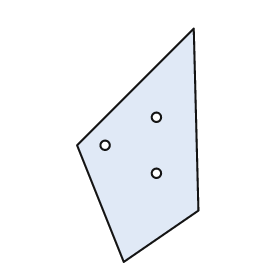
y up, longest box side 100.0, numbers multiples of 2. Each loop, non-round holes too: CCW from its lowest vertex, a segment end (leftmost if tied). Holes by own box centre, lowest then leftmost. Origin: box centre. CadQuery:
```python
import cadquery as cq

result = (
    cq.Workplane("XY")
    .moveTo(-6.0, -50.0)
    .lineTo(26.0, -28.0)
    .lineTo(24.0, 50.0)
    .lineTo(-26.0, 0.0)
    .close()
    .moveTo(8.0, -12.0)
    .circle(2.0)
    .moveTo(-14.0, 0.0)
    .circle(2.0)
    .moveTo(8.0, 12.0)
    .circle(2.0)
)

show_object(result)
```